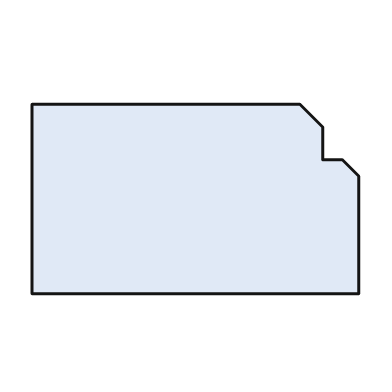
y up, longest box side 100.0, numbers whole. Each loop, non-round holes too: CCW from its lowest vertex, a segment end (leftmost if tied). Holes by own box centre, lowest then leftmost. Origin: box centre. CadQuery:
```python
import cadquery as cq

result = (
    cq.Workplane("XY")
    .moveTo(-50.0, -29.0)
    .lineTo(50.0, -29.0)
    .lineTo(50.0, 7.0)
    .lineTo(45.0, 12.0)
    .lineTo(39.0, 12.0)
    .lineTo(39.0, 22.0)
    .lineTo(32.0, 29.0)
    .lineTo(-50.0, 29.0)
    .close()
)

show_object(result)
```